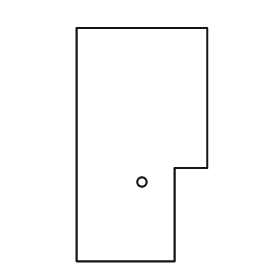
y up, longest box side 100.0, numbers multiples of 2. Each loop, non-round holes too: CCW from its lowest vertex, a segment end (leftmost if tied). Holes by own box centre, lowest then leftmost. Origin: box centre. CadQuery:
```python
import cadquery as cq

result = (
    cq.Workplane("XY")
    .moveTo(-28.0, -50.0)
    .lineTo(14.0, -50.0)
    .lineTo(14.0, -10.0)
    .lineTo(28.0, -10.0)
    .lineTo(28.0, 50.0)
    .lineTo(-28.0, 50.0)
    .close()
    .moveTo(0.0, -16.0)
    .circle(2.0)
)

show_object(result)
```